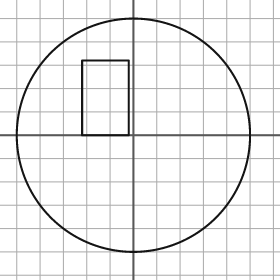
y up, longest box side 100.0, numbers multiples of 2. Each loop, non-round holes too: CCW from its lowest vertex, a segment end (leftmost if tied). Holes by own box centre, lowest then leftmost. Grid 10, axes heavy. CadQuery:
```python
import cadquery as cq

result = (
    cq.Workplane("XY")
    .moveTo(0.0, 0.0)
    .circle(50.0)
    .moveTo(-22.0, 0.0)
    .lineTo(-2.0, 0.0)
    .lineTo(-2.0, 32.0)
    .lineTo(-22.0, 32.0)
    .close()
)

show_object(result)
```